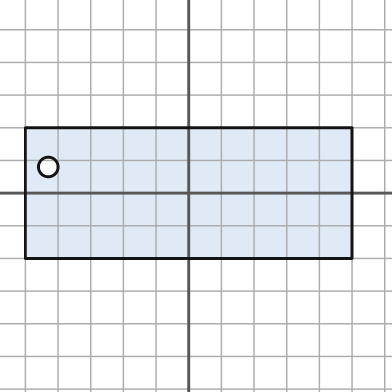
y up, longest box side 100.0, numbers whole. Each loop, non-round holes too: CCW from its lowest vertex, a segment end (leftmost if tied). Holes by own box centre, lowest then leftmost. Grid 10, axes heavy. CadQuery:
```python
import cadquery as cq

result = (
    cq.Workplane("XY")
    .moveTo(-50.0, -20.0)
    .lineTo(50.0, -20.0)
    .lineTo(50.0, 20.0)
    .lineTo(-50.0, 20.0)
    .close()
    .moveTo(-43.0, 8.0)
    .circle(3.0)
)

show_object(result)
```